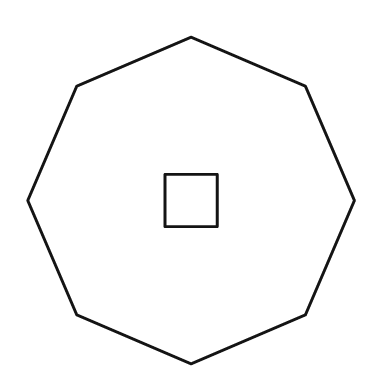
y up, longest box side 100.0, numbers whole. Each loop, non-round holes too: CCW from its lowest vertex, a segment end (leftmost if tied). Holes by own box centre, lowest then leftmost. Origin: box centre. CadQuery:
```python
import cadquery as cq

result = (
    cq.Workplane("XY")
    .moveTo(0.0, -50.0)
    .lineTo(35.0, -35.0)
    .lineTo(50.0, 0.0)
    .lineTo(35.0, 35.0)
    .lineTo(0.0, 50.0)
    .lineTo(-35.0, 35.0)
    .lineTo(-50.0, 0.0)
    .lineTo(-35.0, -35.0)
    .close()
    .moveTo(-8.0, -8.0)
    .lineTo(8.0, -8.0)
    .lineTo(8.0, 8.0)
    .lineTo(-8.0, 8.0)
    .close()
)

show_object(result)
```